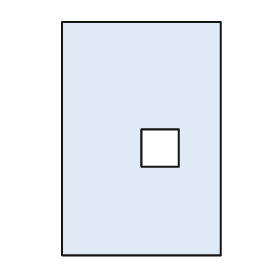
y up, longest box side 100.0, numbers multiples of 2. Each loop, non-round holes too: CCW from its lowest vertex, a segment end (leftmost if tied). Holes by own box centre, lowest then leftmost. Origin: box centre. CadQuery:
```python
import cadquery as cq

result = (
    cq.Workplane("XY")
    .moveTo(-34.0, -50.0)
    .lineTo(34.0, -50.0)
    .lineTo(34.0, 50.0)
    .lineTo(-34.0, 50.0)
    .close()
    .moveTo(0.0, -12.0)
    .lineTo(16.0, -12.0)
    .lineTo(16.0, 4.0)
    .lineTo(0.0, 4.0)
    .close()
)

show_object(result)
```